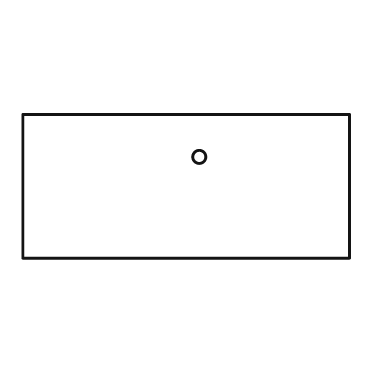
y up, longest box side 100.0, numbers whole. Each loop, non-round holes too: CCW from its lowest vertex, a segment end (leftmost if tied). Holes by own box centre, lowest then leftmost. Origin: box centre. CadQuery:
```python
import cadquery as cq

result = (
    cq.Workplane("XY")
    .moveTo(-50.0, -22.0)
    .lineTo(50.0, -22.0)
    .lineTo(50.0, 22.0)
    .lineTo(-50.0, 22.0)
    .close()
    .moveTo(4.0, 9.0)
    .circle(2.0)
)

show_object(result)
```